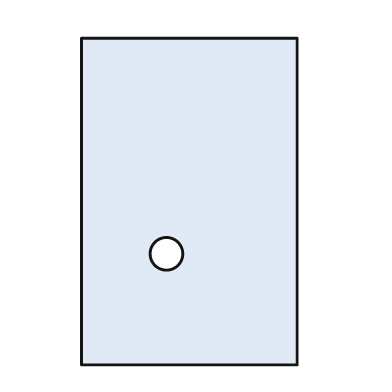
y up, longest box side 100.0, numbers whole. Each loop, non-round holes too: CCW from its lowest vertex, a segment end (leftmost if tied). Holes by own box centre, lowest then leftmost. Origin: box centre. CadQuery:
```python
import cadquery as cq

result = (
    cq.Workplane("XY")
    .moveTo(-33.0, -50.0)
    .lineTo(33.0, -50.0)
    .lineTo(33.0, 50.0)
    .lineTo(-33.0, 50.0)
    .close()
    .moveTo(-7.0, -16.0)
    .circle(5.0)
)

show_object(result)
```